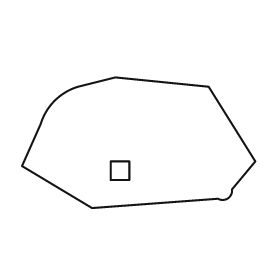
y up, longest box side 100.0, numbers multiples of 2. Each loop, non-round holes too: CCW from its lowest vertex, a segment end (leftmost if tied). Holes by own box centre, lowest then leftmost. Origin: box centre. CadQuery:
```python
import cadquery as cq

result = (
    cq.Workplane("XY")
    .moveTo(-20.0, -28.0)
    .lineTo(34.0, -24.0)
    .threePointArc((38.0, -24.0), (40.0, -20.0))
    .lineTo(50.0, -8.0)
    .lineTo(30.0, 24.0)
    .lineTo(-10.0, 28.0)
    .lineTo(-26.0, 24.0)
    .threePointArc((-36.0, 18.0), (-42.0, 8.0))
    .lineTo(-50.0, -10.0)
    .close()
    .moveTo(-12.0, -16.0)
    .lineTo(-4.0, -16.0)
    .lineTo(-4.0, -8.0)
    .lineTo(-12.0, -8.0)
    .close()
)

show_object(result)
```